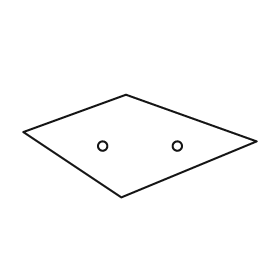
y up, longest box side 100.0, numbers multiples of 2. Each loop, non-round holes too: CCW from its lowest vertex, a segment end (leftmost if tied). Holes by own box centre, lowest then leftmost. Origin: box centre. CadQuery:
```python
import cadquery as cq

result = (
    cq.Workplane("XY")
    .moveTo(-8.0, -22.0)
    .lineTo(50.0, 2.0)
    .lineTo(-6.0, 22.0)
    .lineTo(-50.0, 6.0)
    .close()
    .moveTo(-16.0, 0.0)
    .circle(2.0)
    .moveTo(16.0, 0.0)
    .circle(2.0)
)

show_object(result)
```